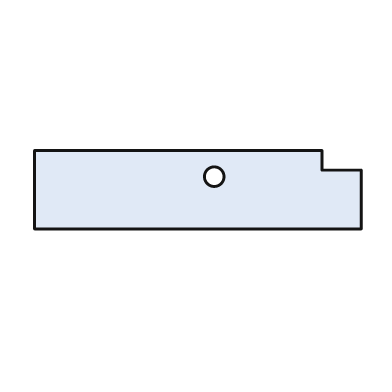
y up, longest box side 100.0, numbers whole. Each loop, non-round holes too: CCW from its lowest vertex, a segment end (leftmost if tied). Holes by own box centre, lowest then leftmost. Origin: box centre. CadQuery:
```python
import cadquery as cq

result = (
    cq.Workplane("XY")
    .moveTo(-50.0, -12.0)
    .lineTo(50.0, -12.0)
    .lineTo(50.0, 6.0)
    .lineTo(38.0, 6.0)
    .lineTo(38.0, 12.0)
    .lineTo(-50.0, 12.0)
    .close()
    .moveTo(5.0, 4.0)
    .circle(3.0)
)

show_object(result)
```